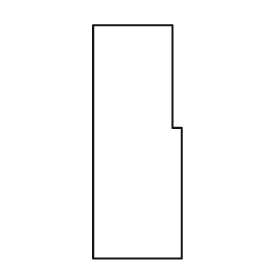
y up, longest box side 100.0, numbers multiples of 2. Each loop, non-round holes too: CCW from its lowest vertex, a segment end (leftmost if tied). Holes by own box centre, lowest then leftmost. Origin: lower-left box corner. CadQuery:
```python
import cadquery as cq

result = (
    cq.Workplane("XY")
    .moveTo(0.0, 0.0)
    .lineTo(38.0, 0.0)
    .lineTo(38.0, 56.0)
    .lineTo(34.0, 56.0)
    .lineTo(34.0, 100.0)
    .lineTo(0.0, 100.0)
    .close()
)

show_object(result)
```